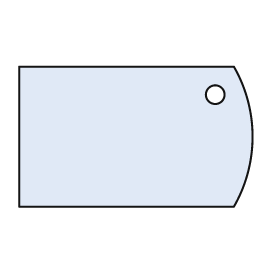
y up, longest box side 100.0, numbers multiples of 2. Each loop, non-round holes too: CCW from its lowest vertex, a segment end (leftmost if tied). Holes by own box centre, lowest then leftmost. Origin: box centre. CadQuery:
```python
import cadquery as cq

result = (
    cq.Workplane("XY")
    .moveTo(-50.0, -30.0)
    .lineTo(42.0, -30.0)
    .threePointArc((50.0, 0.0), (42.0, 30.0))
    .lineTo(-50.0, 30.0)
    .close()
    .moveTo(34.0, 18.0)
    .circle(4.0)
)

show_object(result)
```